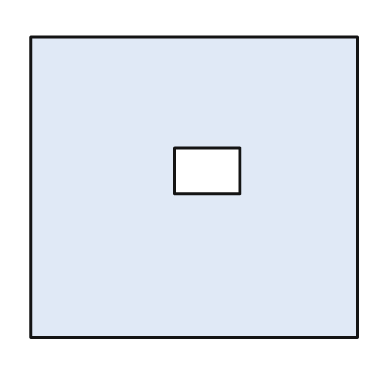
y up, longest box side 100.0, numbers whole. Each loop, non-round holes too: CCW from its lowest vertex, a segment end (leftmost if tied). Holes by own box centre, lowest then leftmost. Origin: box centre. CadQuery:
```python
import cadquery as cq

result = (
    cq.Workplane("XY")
    .moveTo(-50.0, -46.0)
    .lineTo(50.0, -46.0)
    .lineTo(50.0, 46.0)
    .lineTo(-50.0, 46.0)
    .close()
    .moveTo(-6.0, -2.0)
    .lineTo(14.0, -2.0)
    .lineTo(14.0, 12.0)
    .lineTo(-6.0, 12.0)
    .close()
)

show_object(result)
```